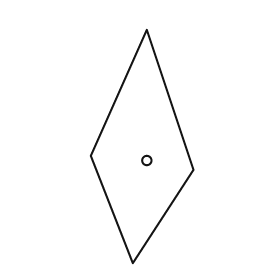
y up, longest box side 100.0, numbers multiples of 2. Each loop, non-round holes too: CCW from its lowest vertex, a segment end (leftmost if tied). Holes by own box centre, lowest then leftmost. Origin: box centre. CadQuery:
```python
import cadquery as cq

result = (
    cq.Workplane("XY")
    .moveTo(-4.0, -50.0)
    .lineTo(22.0, -10.0)
    .lineTo(2.0, 50.0)
    .lineTo(-22.0, -4.0)
    .close()
    .moveTo(2.0, -6.0)
    .circle(2.0)
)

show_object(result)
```